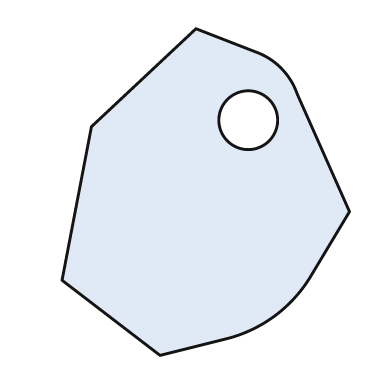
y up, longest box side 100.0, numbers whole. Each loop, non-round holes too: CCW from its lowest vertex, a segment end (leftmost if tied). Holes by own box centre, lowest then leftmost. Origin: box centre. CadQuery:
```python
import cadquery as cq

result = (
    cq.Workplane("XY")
    .moveTo(-14.0, -50.0)
    .lineTo(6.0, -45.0)
    .threePointArc((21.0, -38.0), (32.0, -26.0))
    .lineTo(44.0, -6.0)
    .lineTo(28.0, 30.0)
    .threePointArc((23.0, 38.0), (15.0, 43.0))
    .lineTo(-3.0, 50.0)
    .lineTo(-35.0, 20.0)
    .lineTo(-44.0, -27.0)
    .close()
    .moveTo(13.0, 22.0)
    .circle(9.0)
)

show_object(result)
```